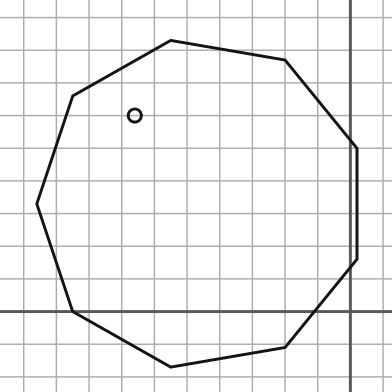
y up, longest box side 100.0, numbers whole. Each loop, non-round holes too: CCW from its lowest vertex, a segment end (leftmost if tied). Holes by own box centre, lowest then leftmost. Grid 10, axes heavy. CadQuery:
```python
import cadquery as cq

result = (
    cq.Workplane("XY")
    .moveTo(-55.0, -17.0)
    .lineTo(-20.0, -11.0)
    .lineTo(2.0, 16.0)
    .lineTo(2.0, 50.0)
    .lineTo(-20.0, 77.0)
    .lineTo(-55.0, 83.0)
    .lineTo(-85.0, 66.0)
    .lineTo(-96.0, 33.0)
    .lineTo(-85.0, 0.0)
    .close()
    .moveTo(-66.0, 60.0)
    .circle(2.0)
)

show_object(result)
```